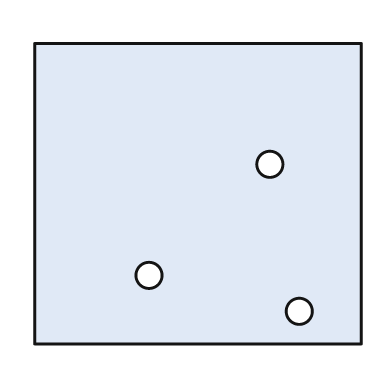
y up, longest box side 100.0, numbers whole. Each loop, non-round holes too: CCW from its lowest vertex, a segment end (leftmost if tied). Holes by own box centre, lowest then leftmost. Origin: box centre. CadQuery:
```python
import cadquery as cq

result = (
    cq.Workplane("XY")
    .moveTo(-50.0, -46.0)
    .lineTo(50.0, -46.0)
    .lineTo(50.0, 46.0)
    .lineTo(-50.0, 46.0)
    .close()
    .moveTo(31.0, -36.0)
    .circle(4.0)
    .moveTo(-15.0, -25.0)
    .circle(4.0)
    .moveTo(22.0, 9.0)
    .circle(4.0)
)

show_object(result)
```